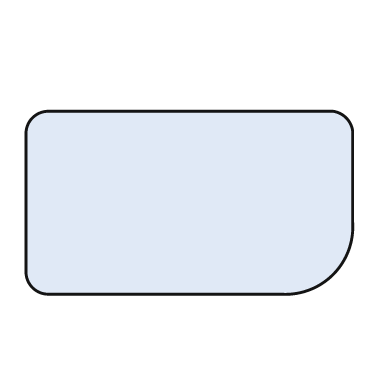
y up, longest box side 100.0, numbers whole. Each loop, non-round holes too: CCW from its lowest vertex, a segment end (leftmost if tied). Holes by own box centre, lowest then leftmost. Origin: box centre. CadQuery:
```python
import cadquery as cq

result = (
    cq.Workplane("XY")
    .moveTo(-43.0, -28.0)
    .lineTo(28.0, -28.0)
    .threePointArc((44.0, -22.0), (50.0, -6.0))
    .lineTo(50.0, 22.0)
    .threePointArc((48.0, 26.0), (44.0, 28.0))
    .lineTo(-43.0, 28.0)
    .threePointArc((-48.0, 26.0), (-50.0, 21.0))
    .lineTo(-50.0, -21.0)
    .threePointArc((-48.0, -26.0), (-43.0, -28.0))
    .close()
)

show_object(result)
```